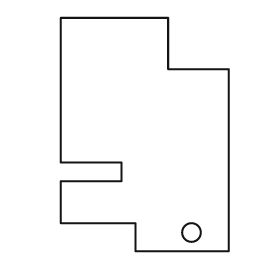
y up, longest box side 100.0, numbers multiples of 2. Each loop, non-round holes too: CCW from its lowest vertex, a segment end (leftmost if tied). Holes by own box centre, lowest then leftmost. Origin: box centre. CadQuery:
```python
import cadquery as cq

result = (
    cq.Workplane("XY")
    .moveTo(-4.0, -50.0)
    .lineTo(36.0, -50.0)
    .lineTo(36.0, 28.0)
    .lineTo(10.0, 28.0)
    .lineTo(10.0, 50.0)
    .lineTo(-36.0, 50.0)
    .lineTo(-36.0, -12.0)
    .lineTo(-10.0, -12.0)
    .lineTo(-10.0, -20.0)
    .lineTo(-36.0, -20.0)
    .lineTo(-36.0, -38.0)
    .lineTo(-4.0, -38.0)
    .close()
    .moveTo(20.0, -42.0)
    .circle(4.0)
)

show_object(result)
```